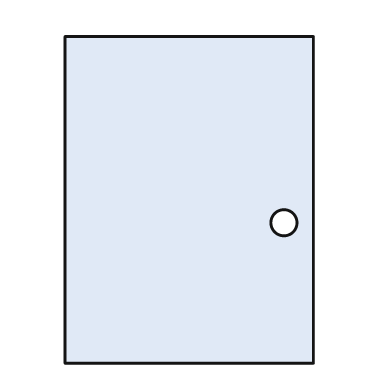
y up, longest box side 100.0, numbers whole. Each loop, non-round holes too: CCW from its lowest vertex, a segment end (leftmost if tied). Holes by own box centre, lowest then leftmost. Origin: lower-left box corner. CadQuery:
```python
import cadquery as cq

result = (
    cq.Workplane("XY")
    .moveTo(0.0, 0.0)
    .lineTo(76.0, 0.0)
    .lineTo(76.0, 100.0)
    .lineTo(0.0, 100.0)
    .close()
    .moveTo(67.0, 43.0)
    .circle(4.0)
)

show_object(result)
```